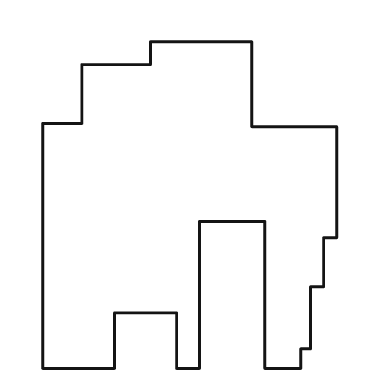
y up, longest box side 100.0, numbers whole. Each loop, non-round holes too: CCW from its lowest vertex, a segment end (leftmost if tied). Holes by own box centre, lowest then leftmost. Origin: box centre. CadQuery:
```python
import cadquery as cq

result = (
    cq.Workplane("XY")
    .moveTo(-45.0, -50.0)
    .lineTo(-23.0, -50.0)
    .lineTo(-23.0, -33.0)
    .lineTo(-4.0, -33.0)
    .lineTo(-4.0, -50.0)
    .lineTo(3.0, -50.0)
    .lineTo(3.0, -5.0)
    .lineTo(23.0, -5.0)
    .lineTo(23.0, -50.0)
    .lineTo(34.0, -50.0)
    .lineTo(34.0, -44.0)
    .lineTo(37.0, -44.0)
    .lineTo(37.0, -25.0)
    .lineTo(41.0, -25.0)
    .lineTo(41.0, -10.0)
    .lineTo(45.0, -10.0)
    .lineTo(45.0, 24.0)
    .lineTo(19.0, 24.0)
    .lineTo(19.0, 50.0)
    .lineTo(-12.0, 50.0)
    .lineTo(-12.0, 43.0)
    .lineTo(-33.0, 43.0)
    .lineTo(-33.0, 25.0)
    .lineTo(-45.0, 25.0)
    .close()
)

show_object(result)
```